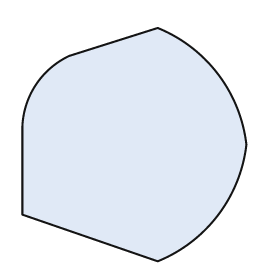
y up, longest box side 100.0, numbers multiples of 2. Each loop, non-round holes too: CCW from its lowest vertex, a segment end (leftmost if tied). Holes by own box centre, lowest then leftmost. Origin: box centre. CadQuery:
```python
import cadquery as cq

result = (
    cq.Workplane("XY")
    .moveTo(10.0, -50.0)
    .threePointArc((36.0, -30.0), (48.0, 0.0))
    .threePointArc((36.0, 30.0), (10.0, 50.0))
    .lineTo(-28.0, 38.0)
    .threePointArc((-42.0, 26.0), (-48.0, 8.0))
    .lineTo(-48.0, -30.0)
    .close()
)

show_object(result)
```